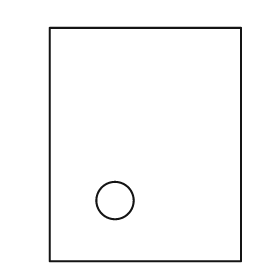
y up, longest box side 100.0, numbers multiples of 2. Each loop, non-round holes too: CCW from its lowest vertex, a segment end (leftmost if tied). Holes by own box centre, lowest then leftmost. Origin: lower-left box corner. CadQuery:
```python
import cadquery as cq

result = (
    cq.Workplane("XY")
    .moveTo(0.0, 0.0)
    .lineTo(82.0, 0.0)
    .lineTo(82.0, 100.0)
    .lineTo(0.0, 100.0)
    .close()
    .moveTo(28.0, 26.0)
    .circle(8.0)
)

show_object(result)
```